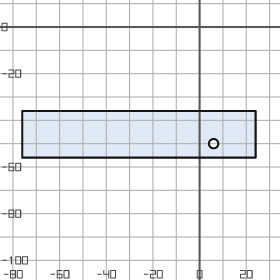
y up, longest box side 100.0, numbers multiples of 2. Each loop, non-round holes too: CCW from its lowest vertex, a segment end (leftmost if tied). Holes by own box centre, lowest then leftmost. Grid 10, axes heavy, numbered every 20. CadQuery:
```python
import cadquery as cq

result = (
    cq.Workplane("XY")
    .moveTo(-76.0, -56.0)
    .lineTo(24.0, -56.0)
    .lineTo(24.0, -36.0)
    .lineTo(-76.0, -36.0)
    .close()
    .moveTo(6.0, -50.0)
    .circle(2.0)
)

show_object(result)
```